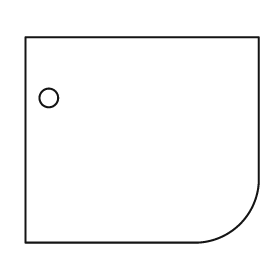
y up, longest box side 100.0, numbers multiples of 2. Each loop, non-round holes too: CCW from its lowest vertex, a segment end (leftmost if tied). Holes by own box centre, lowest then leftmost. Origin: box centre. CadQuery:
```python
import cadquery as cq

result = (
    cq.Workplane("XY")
    .moveTo(-50.0, -44.0)
    .lineTo(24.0, -44.0)
    .threePointArc((42.0, -36.0), (50.0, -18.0))
    .lineTo(50.0, 44.0)
    .lineTo(-50.0, 44.0)
    .close()
    .moveTo(-40.0, 18.0)
    .circle(4.0)
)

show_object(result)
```